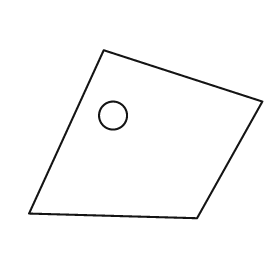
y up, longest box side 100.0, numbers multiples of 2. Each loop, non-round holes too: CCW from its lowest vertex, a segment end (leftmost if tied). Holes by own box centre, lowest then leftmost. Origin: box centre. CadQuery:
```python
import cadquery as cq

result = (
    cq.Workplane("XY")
    .moveTo(22.0, -36.0)
    .lineTo(50.0, 14.0)
    .lineTo(-18.0, 36.0)
    .lineTo(-50.0, -34.0)
    .close()
    .moveTo(-14.0, 8.0)
    .circle(6.0)
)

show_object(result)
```